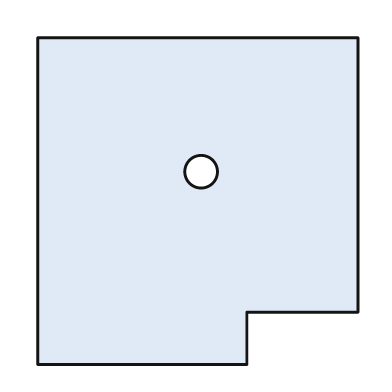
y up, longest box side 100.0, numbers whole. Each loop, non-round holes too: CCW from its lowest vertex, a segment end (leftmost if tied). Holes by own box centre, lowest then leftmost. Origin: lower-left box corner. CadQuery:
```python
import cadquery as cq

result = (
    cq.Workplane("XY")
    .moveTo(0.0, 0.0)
    .lineTo(64.0, 0.0)
    .lineTo(64.0, 16.0)
    .lineTo(98.0, 16.0)
    .lineTo(98.0, 100.0)
    .lineTo(0.0, 100.0)
    .close()
    .moveTo(50.0, 59.0)
    .circle(5.0)
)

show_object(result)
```